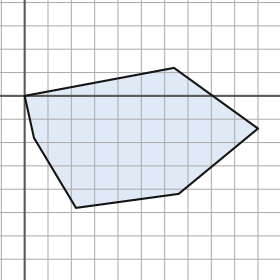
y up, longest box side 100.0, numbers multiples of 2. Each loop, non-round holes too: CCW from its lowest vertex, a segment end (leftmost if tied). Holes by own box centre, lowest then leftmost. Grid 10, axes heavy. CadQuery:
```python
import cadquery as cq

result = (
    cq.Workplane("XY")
    .moveTo(22.0, -48.0)
    .lineTo(66.0, -42.0)
    .lineTo(100.0, -14.0)
    .lineTo(64.0, 12.0)
    .lineTo(0.0, 0.0)
    .lineTo(4.0, -18.0)
    .close()
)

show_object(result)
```